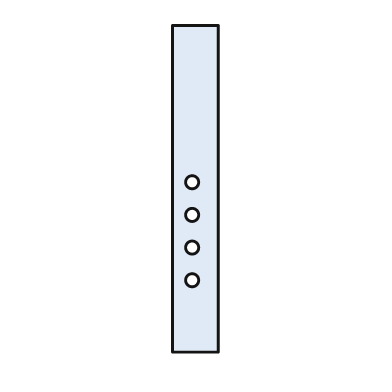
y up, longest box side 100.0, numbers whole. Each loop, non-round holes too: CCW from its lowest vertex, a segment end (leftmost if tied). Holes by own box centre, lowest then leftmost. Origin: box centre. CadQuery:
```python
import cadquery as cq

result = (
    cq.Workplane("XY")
    .moveTo(-7.0, -50.0)
    .lineTo(7.0, -50.0)
    .lineTo(7.0, 50.0)
    .lineTo(-7.0, 50.0)
    .close()
    .moveTo(-1.0, -28.0)
    .circle(2.0)
    .moveTo(-1.0, -18.0)
    .circle(2.0)
    .moveTo(-1.0, -8.0)
    .circle(2.0)
    .moveTo(-1.0, 2.0)
    .circle(2.0)
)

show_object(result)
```